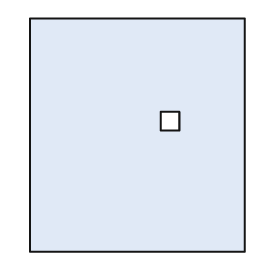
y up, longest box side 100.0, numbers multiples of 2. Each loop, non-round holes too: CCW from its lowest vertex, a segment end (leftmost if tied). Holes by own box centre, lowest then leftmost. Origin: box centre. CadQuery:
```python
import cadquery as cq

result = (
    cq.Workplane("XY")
    .moveTo(-46.0, -50.0)
    .lineTo(46.0, -50.0)
    .lineTo(46.0, 50.0)
    .lineTo(-46.0, 50.0)
    .close()
    .moveTo(10.0, 2.0)
    .lineTo(18.0, 2.0)
    .lineTo(18.0, 10.0)
    .lineTo(10.0, 10.0)
    .close()
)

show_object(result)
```